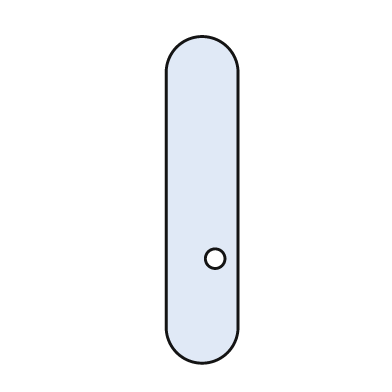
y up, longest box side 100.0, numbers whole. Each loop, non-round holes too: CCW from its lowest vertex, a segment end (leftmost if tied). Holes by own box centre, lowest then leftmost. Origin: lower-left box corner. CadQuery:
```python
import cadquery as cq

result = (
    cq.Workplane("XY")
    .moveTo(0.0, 11.0)
    .threePointArc((11.0, 0.0), (22.0, 11.0))
    .lineTo(22.0, 89.0)
    .threePointArc((11.0, 100.0), (0.0, 89.0))
    .close()
    .moveTo(15.0, 32.0)
    .circle(3.0)
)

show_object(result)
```